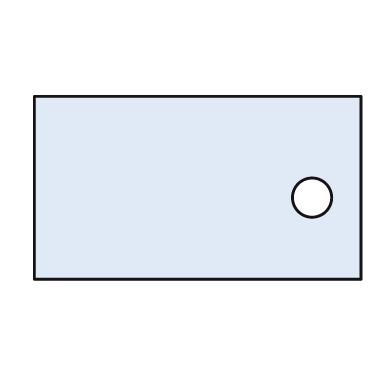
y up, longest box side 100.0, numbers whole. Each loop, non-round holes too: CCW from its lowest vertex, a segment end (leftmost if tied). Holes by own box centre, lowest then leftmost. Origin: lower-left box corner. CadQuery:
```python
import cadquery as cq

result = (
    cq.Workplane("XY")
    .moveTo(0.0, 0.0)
    .lineTo(100.0, 0.0)
    .lineTo(100.0, 56.0)
    .lineTo(0.0, 56.0)
    .close()
    .moveTo(85.0, 25.0)
    .circle(6.0)
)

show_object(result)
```